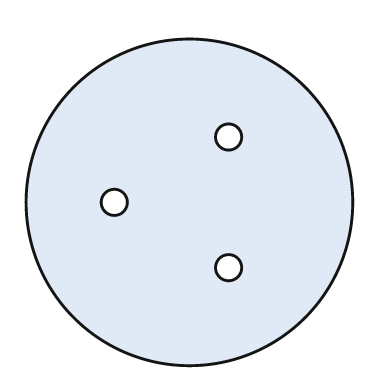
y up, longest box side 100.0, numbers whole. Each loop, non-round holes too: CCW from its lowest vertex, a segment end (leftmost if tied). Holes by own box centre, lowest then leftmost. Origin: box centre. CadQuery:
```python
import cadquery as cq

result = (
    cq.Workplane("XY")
    .moveTo(0.0, 0.0)
    .circle(50.0)
    .moveTo(12.0, -20.0)
    .circle(4.0)
    .moveTo(-23.0, 0.0)
    .circle(4.0)
    .moveTo(12.0, 20.0)
    .circle(4.0)
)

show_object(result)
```